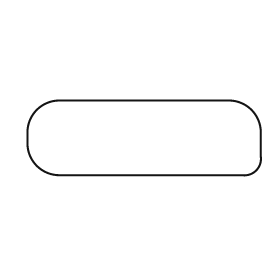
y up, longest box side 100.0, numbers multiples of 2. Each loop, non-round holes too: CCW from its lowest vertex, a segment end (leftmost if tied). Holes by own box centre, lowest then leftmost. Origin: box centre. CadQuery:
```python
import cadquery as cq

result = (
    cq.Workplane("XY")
    .moveTo(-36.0, -16.0)
    .lineTo(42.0, -16.0)
    .threePointArc((48.0, -14.0), (50.0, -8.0))
    .lineTo(50.0, 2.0)
    .threePointArc((46.0, 12.0), (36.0, 16.0))
    .lineTo(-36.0, 16.0)
    .threePointArc((-46.0, 12.0), (-50.0, 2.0))
    .lineTo(-50.0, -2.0)
    .threePointArc((-46.0, -12.0), (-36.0, -16.0))
    .close()
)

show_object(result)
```